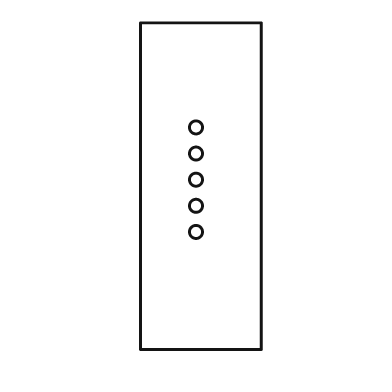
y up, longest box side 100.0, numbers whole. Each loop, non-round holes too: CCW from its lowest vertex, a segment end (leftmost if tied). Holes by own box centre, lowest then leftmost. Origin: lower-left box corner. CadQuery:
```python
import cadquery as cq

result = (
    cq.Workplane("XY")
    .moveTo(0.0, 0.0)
    .lineTo(37.0, 0.0)
    .lineTo(37.0, 100.0)
    .lineTo(0.0, 100.0)
    .close()
    .moveTo(17.0, 36.0)
    .circle(2.0)
    .moveTo(17.0, 44.0)
    .circle(2.0)
    .moveTo(17.0, 52.0)
    .circle(2.0)
    .moveTo(17.0, 60.0)
    .circle(2.0)
    .moveTo(17.0, 68.0)
    .circle(2.0)
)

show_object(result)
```